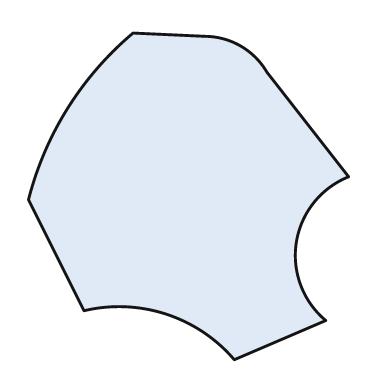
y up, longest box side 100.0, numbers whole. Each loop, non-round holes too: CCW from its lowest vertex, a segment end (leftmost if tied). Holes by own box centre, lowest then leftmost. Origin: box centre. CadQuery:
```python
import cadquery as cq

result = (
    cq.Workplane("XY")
    .moveTo(14.0, -50.0)
    .lineTo(42.0, -38.0)
    .threePointArc((33.0, -14.0), (49.0, 6.0))
    .lineTo(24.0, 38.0)
    .threePointArc((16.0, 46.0), (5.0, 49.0))
    .lineTo(-17.0, 50.0)
    .threePointArc((-37.0, 27.0), (-49.0, -1.0))
    .lineTo(-32.0, -35.0)
    .threePointArc((-7.0, -36.0), (14.0, -50.0))
    .close()
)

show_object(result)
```